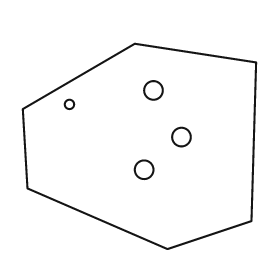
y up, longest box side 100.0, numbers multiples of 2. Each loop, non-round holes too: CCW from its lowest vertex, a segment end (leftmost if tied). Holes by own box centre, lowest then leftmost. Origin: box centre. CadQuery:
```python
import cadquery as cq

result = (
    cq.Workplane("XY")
    .moveTo(12.0, -44.0)
    .lineTo(48.0, -32.0)
    .lineTo(50.0, 36.0)
    .lineTo(-2.0, 44.0)
    .lineTo(-50.0, 16.0)
    .lineTo(-48.0, -18.0)
    .close()
    .moveTo(2.0, -10.0)
    .circle(4.0)
    .moveTo(18.0, 4.0)
    .circle(4.0)
    .moveTo(-30.0, 18.0)
    .circle(2.0)
    .moveTo(6.0, 24.0)
    .circle(4.0)
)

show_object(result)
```